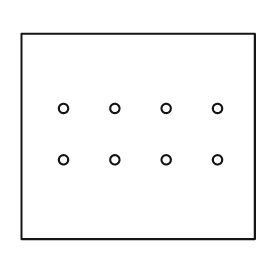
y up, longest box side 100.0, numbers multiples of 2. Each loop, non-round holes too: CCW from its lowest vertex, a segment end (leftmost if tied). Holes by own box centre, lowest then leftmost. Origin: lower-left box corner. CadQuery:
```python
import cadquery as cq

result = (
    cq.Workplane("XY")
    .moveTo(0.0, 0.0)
    .lineTo(100.0, 0.0)
    .lineTo(100.0, 88.0)
    .lineTo(0.0, 88.0)
    .close()
    .moveTo(18.0, 34.0)
    .circle(2.0)
    .moveTo(40.0, 34.0)
    .circle(2.0)
    .moveTo(62.0, 34.0)
    .circle(2.0)
    .moveTo(84.0, 34.0)
    .circle(2.0)
    .moveTo(18.0, 56.0)
    .circle(2.0)
    .moveTo(40.0, 56.0)
    .circle(2.0)
    .moveTo(62.0, 56.0)
    .circle(2.0)
    .moveTo(84.0, 56.0)
    .circle(2.0)
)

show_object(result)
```